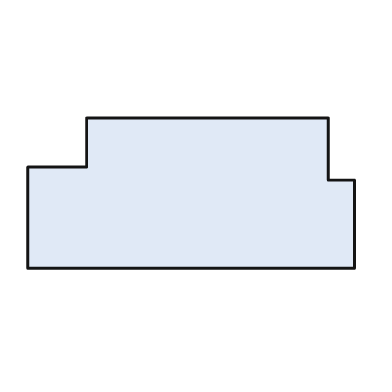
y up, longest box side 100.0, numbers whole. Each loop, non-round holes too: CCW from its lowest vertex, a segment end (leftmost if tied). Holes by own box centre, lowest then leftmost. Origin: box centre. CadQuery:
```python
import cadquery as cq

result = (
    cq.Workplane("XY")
    .moveTo(-50.0, -23.0)
    .lineTo(50.0, -23.0)
    .lineTo(50.0, 4.0)
    .lineTo(42.0, 4.0)
    .lineTo(42.0, 23.0)
    .lineTo(-32.0, 23.0)
    .lineTo(-32.0, 8.0)
    .lineTo(-50.0, 8.0)
    .close()
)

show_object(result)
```